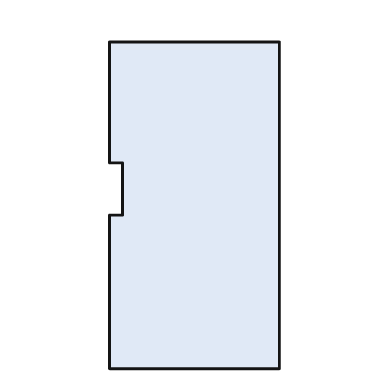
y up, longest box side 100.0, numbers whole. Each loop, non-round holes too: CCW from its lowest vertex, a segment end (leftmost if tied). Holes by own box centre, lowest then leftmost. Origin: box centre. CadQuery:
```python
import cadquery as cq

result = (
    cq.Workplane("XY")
    .moveTo(-26.0, -50.0)
    .lineTo(26.0, -50.0)
    .lineTo(26.0, 50.0)
    .lineTo(-26.0, 50.0)
    .lineTo(-26.0, 13.0)
    .lineTo(-22.0, 13.0)
    .lineTo(-22.0, -3.0)
    .lineTo(-26.0, -3.0)
    .close()
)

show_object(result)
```